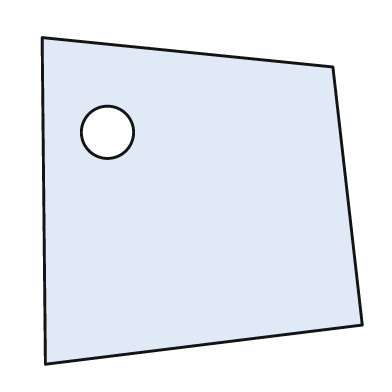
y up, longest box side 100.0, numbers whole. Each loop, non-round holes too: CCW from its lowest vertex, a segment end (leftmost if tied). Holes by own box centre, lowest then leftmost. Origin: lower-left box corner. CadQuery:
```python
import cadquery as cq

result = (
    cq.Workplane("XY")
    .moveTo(1.0, 0.0)
    .lineTo(98.0, 12.0)
    .lineTo(89.0, 91.0)
    .lineTo(0.0, 100.0)
    .close()
    .moveTo(20.0, 71.0)
    .circle(8.0)
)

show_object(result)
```